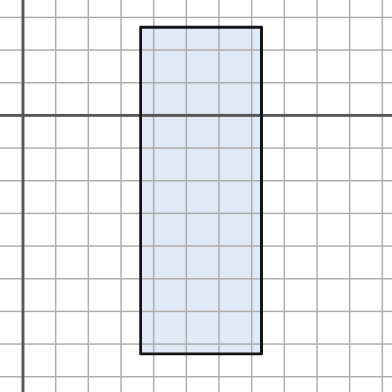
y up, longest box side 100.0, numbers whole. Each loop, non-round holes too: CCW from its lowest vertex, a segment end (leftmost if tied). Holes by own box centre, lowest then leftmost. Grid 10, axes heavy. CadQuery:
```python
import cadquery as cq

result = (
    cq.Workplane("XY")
    .moveTo(36.0, -73.0)
    .lineTo(73.0, -73.0)
    .lineTo(73.0, 27.0)
    .lineTo(36.0, 27.0)
    .close()
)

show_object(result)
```